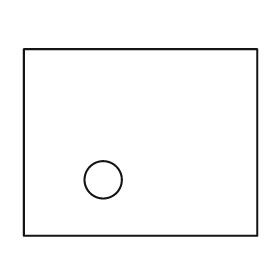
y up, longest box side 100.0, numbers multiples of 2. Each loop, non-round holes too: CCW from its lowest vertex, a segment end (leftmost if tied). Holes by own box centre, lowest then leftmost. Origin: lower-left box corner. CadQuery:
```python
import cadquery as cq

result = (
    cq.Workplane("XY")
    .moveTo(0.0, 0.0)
    .lineTo(100.0, 0.0)
    .lineTo(100.0, 80.0)
    .lineTo(0.0, 80.0)
    .close()
    .moveTo(34.0, 24.0)
    .circle(8.0)
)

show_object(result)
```